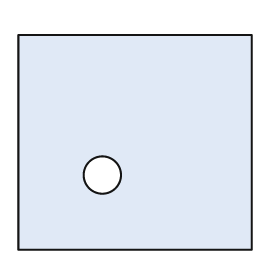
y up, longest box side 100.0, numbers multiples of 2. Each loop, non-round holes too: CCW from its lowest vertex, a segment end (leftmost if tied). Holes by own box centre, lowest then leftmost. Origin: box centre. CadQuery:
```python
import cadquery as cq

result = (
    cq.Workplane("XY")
    .moveTo(-50.0, -46.0)
    .lineTo(50.0, -46.0)
    .lineTo(50.0, 46.0)
    .lineTo(-50.0, 46.0)
    .close()
    .moveTo(-14.0, -14.0)
    .circle(8.0)
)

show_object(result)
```